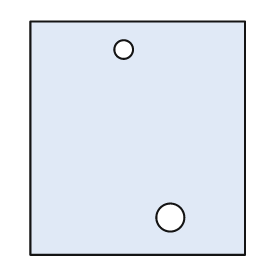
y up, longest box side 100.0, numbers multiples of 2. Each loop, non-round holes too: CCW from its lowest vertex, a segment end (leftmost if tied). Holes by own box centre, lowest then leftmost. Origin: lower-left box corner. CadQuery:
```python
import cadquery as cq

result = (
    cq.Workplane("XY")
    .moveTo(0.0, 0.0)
    .lineTo(92.0, 0.0)
    .lineTo(92.0, 100.0)
    .lineTo(0.0, 100.0)
    .close()
    .moveTo(60.0, 16.0)
    .circle(6.0)
    .moveTo(40.0, 88.0)
    .circle(4.0)
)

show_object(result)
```